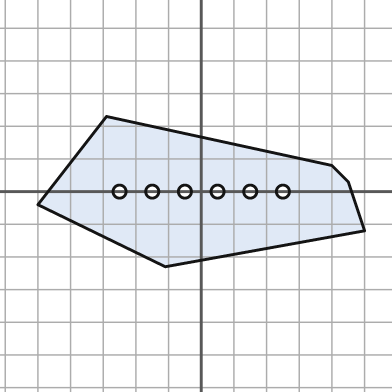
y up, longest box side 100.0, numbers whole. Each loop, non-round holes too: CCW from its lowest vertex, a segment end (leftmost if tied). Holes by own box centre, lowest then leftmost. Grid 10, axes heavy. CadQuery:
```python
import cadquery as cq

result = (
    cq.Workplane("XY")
    .moveTo(-11.0, -23.0)
    .lineTo(50.0, -12.0)
    .lineTo(45.0, 3.0)
    .lineTo(40.0, 8.0)
    .lineTo(-29.0, 23.0)
    .lineTo(-50.0, -4.0)
    .close()
    .moveTo(-25.0, 0.0)
    .circle(2.0)
    .moveTo(-15.0, 0.0)
    .circle(2.0)
    .moveTo(-5.0, 0.0)
    .circle(2.0)
    .moveTo(5.0, 0.0)
    .circle(2.0)
    .moveTo(15.0, 0.0)
    .circle(2.0)
    .moveTo(25.0, 0.0)
    .circle(2.0)
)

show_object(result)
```